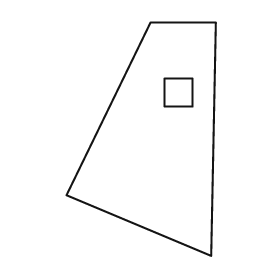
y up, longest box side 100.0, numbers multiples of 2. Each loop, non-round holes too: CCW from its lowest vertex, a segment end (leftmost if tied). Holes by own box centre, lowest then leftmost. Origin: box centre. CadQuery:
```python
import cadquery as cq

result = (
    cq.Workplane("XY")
    .moveTo(30.0, -50.0)
    .lineTo(32.0, 50.0)
    .lineTo(4.0, 50.0)
    .lineTo(-32.0, -24.0)
    .close()
    .moveTo(10.0, 14.0)
    .lineTo(22.0, 14.0)
    .lineTo(22.0, 26.0)
    .lineTo(10.0, 26.0)
    .close()
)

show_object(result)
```